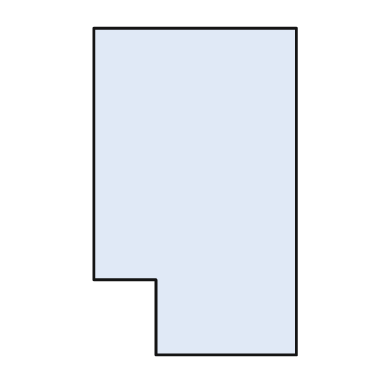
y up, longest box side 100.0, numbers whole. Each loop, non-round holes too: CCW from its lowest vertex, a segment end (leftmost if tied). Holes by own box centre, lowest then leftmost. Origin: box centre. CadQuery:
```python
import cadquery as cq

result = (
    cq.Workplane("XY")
    .moveTo(-12.0, -50.0)
    .lineTo(31.0, -50.0)
    .lineTo(31.0, 50.0)
    .lineTo(-31.0, 50.0)
    .lineTo(-31.0, -27.0)
    .lineTo(-12.0, -27.0)
    .close()
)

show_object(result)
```